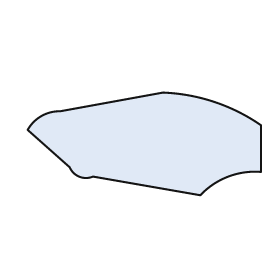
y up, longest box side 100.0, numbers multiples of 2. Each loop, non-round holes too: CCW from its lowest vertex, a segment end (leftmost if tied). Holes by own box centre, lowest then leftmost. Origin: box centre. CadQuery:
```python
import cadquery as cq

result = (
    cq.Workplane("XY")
    .moveTo(24.0, -22.0)
    .threePointArc((36.0, -14.0), (50.0, -12.0))
    .lineTo(50.0, 8.0)
    .threePointArc((30.0, 18.0), (8.0, 22.0))
    .lineTo(-36.0, 14.0)
    .threePointArc((-44.0, 12.0), (-50.0, 6.0))
    .lineTo(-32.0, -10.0)
    .threePointArc((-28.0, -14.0), (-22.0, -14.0))
    .close()
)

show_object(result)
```